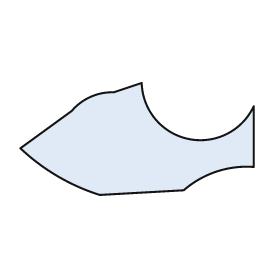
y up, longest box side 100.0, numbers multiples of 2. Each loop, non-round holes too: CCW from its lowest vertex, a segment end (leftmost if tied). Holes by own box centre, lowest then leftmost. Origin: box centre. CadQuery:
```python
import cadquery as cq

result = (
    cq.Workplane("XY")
    .moveTo(-16.0, -24.0)
    .lineTo(20.0, -22.0)
    .threePointArc((34.0, -14.0), (50.0, -12.0))
    .lineTo(50.0, 14.0)
    .threePointArc((22.0, 0.0), (2.0, 24.0))
    .lineTo(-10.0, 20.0)
    .threePointArc((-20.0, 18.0), (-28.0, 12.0))
    .lineTo(-50.0, -4.0)
    .threePointArc((-34.0, -16.0), (-16.0, -24.0))
    .close()
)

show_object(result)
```